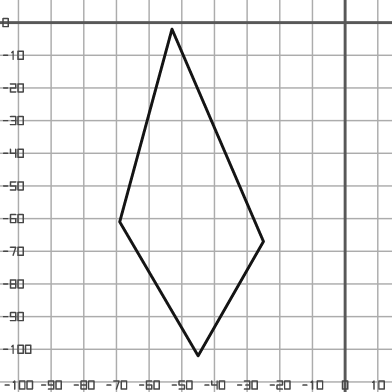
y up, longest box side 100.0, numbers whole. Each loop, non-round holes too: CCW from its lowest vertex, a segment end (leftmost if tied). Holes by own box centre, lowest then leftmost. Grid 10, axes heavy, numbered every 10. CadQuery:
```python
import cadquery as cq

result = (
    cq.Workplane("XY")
    .moveTo(-45.0, -102.0)
    .lineTo(-25.0, -67.0)
    .lineTo(-53.0, -2.0)
    .lineTo(-69.0, -61.0)
    .close()
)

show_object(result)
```